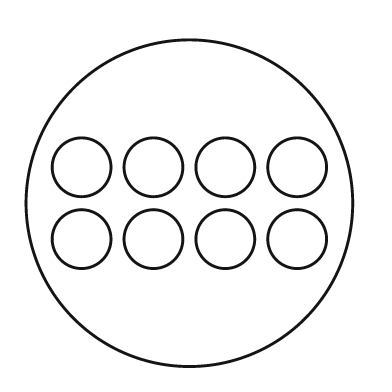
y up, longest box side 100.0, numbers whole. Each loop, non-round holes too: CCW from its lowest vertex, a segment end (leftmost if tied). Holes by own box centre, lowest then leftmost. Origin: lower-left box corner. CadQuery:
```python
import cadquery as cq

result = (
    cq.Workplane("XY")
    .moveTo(50.0, 50.0)
    .circle(50.0)
    .moveTo(17.0, 39.0)
    .circle(9.0)
    .moveTo(39.0, 39.0)
    .circle(9.0)
    .moveTo(61.0, 39.0)
    .circle(9.0)
    .moveTo(83.0, 39.0)
    .circle(9.0)
    .moveTo(17.0, 61.0)
    .circle(9.0)
    .moveTo(39.0, 61.0)
    .circle(9.0)
    .moveTo(61.0, 61.0)
    .circle(9.0)
    .moveTo(83.0, 61.0)
    .circle(9.0)
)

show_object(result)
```